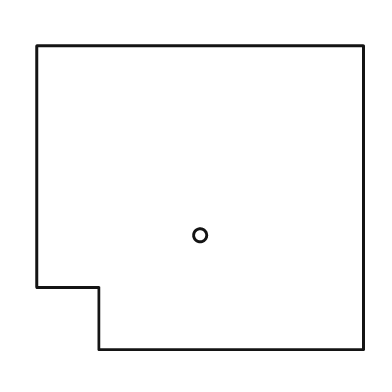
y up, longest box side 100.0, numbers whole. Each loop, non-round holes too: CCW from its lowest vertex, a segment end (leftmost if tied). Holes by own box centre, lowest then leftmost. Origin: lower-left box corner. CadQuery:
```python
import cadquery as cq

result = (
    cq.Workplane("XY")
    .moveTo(19.0, 0.0)
    .lineTo(100.0, 0.0)
    .lineTo(100.0, 93.0)
    .lineTo(0.0, 93.0)
    .lineTo(0.0, 19.0)
    .lineTo(19.0, 19.0)
    .close()
    .moveTo(50.0, 35.0)
    .circle(2.0)
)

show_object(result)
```